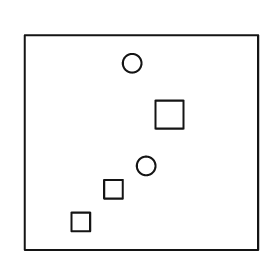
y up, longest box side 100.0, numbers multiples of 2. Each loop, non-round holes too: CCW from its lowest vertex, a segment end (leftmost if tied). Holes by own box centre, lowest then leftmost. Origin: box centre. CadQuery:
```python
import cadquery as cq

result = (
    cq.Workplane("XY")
    .moveTo(-50.0, -46.0)
    .lineTo(50.0, -46.0)
    .lineTo(50.0, 46.0)
    .lineTo(-50.0, 46.0)
    .close()
    .moveTo(-30.0, -38.0)
    .lineTo(-22.0, -38.0)
    .lineTo(-22.0, -30.0)
    .lineTo(-30.0, -30.0)
    .close()
    .moveTo(-16.0, -24.0)
    .lineTo(-8.0, -24.0)
    .lineTo(-8.0, -16.0)
    .lineTo(-16.0, -16.0)
    .close()
    .moveTo(2.0, -10.0)
    .circle(4.0)
    .moveTo(6.0, 6.0)
    .lineTo(18.0, 6.0)
    .lineTo(18.0, 18.0)
    .lineTo(6.0, 18.0)
    .close()
    .moveTo(-4.0, 34.0)
    .circle(4.0)
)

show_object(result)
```